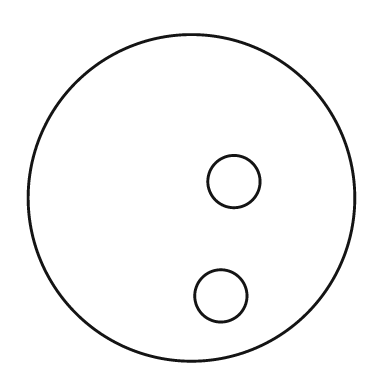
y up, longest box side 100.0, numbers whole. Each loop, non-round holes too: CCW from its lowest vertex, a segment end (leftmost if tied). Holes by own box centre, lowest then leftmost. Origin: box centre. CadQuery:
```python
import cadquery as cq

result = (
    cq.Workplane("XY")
    .moveTo(0.0, 0.0)
    .circle(50.0)
    .moveTo(9.0, -30.0)
    .circle(8.0)
    .moveTo(13.0, 5.0)
    .circle(8.0)
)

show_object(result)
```